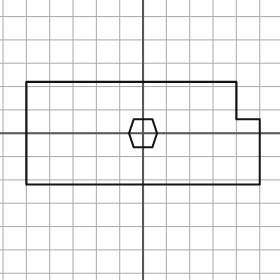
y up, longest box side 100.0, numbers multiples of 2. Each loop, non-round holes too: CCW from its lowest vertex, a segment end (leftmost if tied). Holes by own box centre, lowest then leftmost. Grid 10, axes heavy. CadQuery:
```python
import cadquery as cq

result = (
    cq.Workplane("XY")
    .moveTo(-50.0, -22.0)
    .lineTo(50.0, -22.0)
    .lineTo(50.0, 6.0)
    .lineTo(40.0, 6.0)
    .lineTo(40.0, 22.0)
    .lineTo(-50.0, 22.0)
    .close()
    .moveTo(-4.0, -6.0)
    .lineTo(4.0, -6.0)
    .lineTo(6.0, 0.0)
    .lineTo(4.0, 6.0)
    .lineTo(-4.0, 6.0)
    .lineTo(-6.0, 0.0)
    .close()
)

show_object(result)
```